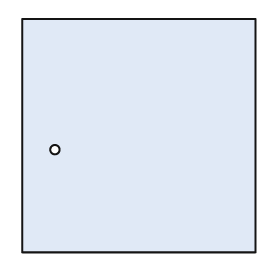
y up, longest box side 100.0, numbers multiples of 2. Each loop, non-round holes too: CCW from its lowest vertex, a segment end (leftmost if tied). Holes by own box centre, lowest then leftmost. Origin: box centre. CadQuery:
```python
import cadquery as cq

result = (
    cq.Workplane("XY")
    .moveTo(-50.0, -50.0)
    .lineTo(50.0, -50.0)
    .lineTo(50.0, 50.0)
    .lineTo(-50.0, 50.0)
    .close()
    .moveTo(-36.0, -6.0)
    .circle(2.0)
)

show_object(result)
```